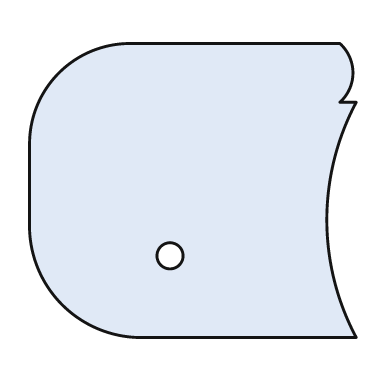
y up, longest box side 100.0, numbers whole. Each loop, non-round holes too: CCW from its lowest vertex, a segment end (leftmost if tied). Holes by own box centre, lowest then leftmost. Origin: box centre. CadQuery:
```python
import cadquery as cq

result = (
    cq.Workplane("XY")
    .moveTo(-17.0, -45.0)
    .lineTo(50.0, -45.0)
    .threePointArc((41.0, -9.0), (50.0, 27.0))
    .lineTo(45.0, 27.0)
    .threePointArc((49.0, 36.0), (45.0, 45.0))
    .lineTo(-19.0, 45.0)
    .threePointArc((-41.0, 36.0), (-50.0, 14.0))
    .lineTo(-50.0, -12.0)
    .threePointArc((-40.0, -35.0), (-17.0, -45.0))
    .close()
    .moveTo(-7.0, -20.0)
    .circle(4.0)
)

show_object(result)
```